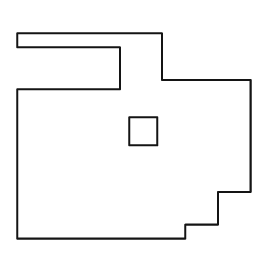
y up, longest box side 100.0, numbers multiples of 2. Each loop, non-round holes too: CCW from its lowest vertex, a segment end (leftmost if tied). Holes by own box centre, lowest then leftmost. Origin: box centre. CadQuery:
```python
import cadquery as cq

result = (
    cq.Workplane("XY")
    .moveTo(-50.0, -44.0)
    .lineTo(22.0, -44.0)
    .lineTo(22.0, -38.0)
    .lineTo(36.0, -38.0)
    .lineTo(36.0, -24.0)
    .lineTo(50.0, -24.0)
    .lineTo(50.0, 24.0)
    .lineTo(12.0, 24.0)
    .lineTo(12.0, 44.0)
    .lineTo(-50.0, 44.0)
    .lineTo(-50.0, 38.0)
    .lineTo(-6.0, 38.0)
    .lineTo(-6.0, 20.0)
    .lineTo(-50.0, 20.0)
    .close()
    .moveTo(-2.0, -4.0)
    .lineTo(10.0, -4.0)
    .lineTo(10.0, 8.0)
    .lineTo(-2.0, 8.0)
    .close()
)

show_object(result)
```